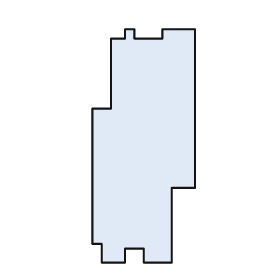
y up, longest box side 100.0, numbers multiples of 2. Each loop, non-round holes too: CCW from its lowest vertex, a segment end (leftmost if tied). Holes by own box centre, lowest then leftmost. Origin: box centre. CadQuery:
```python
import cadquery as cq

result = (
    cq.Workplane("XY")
    .moveTo(-18.0, -50.0)
    .lineTo(-8.0, -50.0)
    .lineTo(-8.0, -44.0)
    .lineTo(0.0, -44.0)
    .lineTo(0.0, -50.0)
    .lineTo(12.0, -50.0)
    .lineTo(12.0, -18.0)
    .lineTo(22.0, -18.0)
    .lineTo(22.0, 50.0)
    .lineTo(8.0, 50.0)
    .lineTo(8.0, 46.0)
    .lineTo(-4.0, 46.0)
    .lineTo(-4.0, 50.0)
    .lineTo(-8.0, 50.0)
    .lineTo(-8.0, 46.0)
    .lineTo(-14.0, 46.0)
    .lineTo(-14.0, 16.0)
    .lineTo(-22.0, 16.0)
    .lineTo(-22.0, -42.0)
    .lineTo(-18.0, -42.0)
    .close()
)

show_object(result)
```